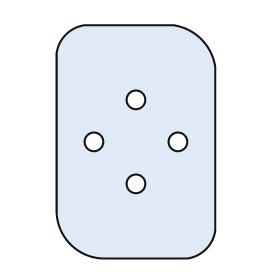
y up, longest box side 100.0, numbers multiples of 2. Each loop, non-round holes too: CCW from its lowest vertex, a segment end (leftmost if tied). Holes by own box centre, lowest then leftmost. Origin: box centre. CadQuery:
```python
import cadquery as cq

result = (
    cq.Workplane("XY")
    .moveTo(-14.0, -50.0)
    .lineTo(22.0, -50.0)
    .threePointArc((30.0, -46.0), (34.0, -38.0))
    .lineTo(34.0, 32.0)
    .threePointArc((28.0, 44.0), (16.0, 50.0))
    .lineTo(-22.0, 50.0)
    .threePointArc((-30.0, 46.0), (-34.0, 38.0))
    .lineTo(-34.0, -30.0)
    .threePointArc((-28.0, -44.0), (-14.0, -50.0))
    .close()
    .moveTo(0.0, -18.0)
    .circle(4.0)
    .moveTo(-18.0, 0.0)
    .circle(4.0)
    .moveTo(18.0, 0.0)
    .circle(4.0)
    .moveTo(0.0, 18.0)
    .circle(4.0)
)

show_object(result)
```